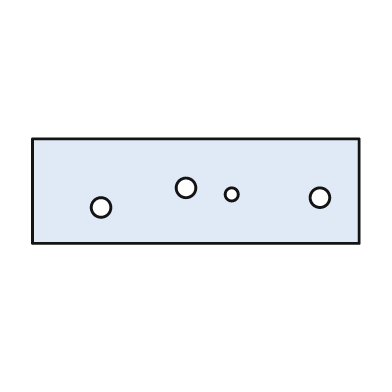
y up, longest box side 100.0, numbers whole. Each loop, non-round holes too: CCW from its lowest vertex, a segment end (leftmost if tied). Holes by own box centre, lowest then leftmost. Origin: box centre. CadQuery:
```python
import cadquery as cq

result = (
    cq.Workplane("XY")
    .moveTo(-50.0, -16.0)
    .lineTo(50.0, -16.0)
    .lineTo(50.0, 16.0)
    .lineTo(-50.0, 16.0)
    .close()
    .moveTo(-29.0, -5.0)
    .circle(3.0)
    .moveTo(38.0, -2.0)
    .circle(3.0)
    .moveTo(11.0, -1.0)
    .circle(2.0)
    .moveTo(-3.0, 1.0)
    .circle(3.0)
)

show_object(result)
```